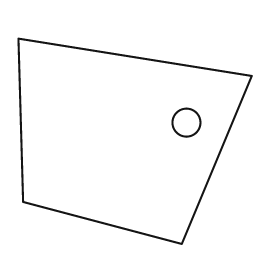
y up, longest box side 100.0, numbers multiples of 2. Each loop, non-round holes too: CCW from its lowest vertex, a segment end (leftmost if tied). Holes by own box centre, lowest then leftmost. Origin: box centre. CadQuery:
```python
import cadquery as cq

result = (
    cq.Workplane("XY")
    .moveTo(20.0, -44.0)
    .lineTo(50.0, 28.0)
    .lineTo(-50.0, 44.0)
    .lineTo(-48.0, -26.0)
    .close()
    .moveTo(22.0, 8.0)
    .circle(6.0)
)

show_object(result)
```